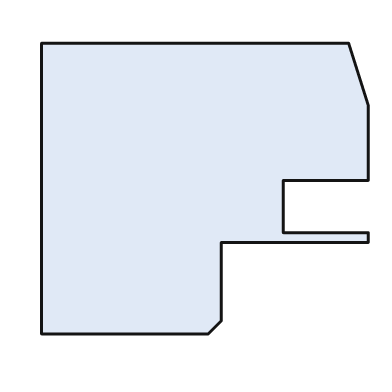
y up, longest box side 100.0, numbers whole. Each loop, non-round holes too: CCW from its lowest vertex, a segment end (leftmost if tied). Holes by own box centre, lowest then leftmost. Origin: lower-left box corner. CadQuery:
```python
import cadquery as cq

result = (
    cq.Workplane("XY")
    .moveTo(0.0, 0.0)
    .lineTo(51.0, 0.0)
    .lineTo(55.0, 4.0)
    .lineTo(55.0, 28.0)
    .lineTo(100.0, 28.0)
    .lineTo(100.0, 31.0)
    .lineTo(74.0, 31.0)
    .lineTo(74.0, 47.0)
    .lineTo(100.0, 47.0)
    .lineTo(100.0, 70.0)
    .lineTo(94.0, 89.0)
    .lineTo(0.0, 89.0)
    .close()
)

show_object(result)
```